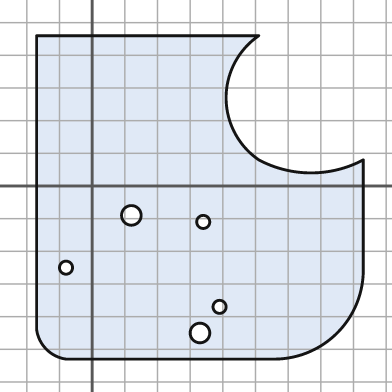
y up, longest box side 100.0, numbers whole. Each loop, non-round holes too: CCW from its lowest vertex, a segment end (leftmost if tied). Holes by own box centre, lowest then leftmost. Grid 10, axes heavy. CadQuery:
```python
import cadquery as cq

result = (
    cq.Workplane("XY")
    .moveTo(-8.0, -53.0)
    .lineTo(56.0, -53.0)
    .threePointArc((75.0, -45.0), (83.0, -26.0))
    .lineTo(83.0, 8.0)
    .threePointArc((67.0, 4.0), (51.0, 8.0))
    .threePointArc((41.0, 27.0), (51.0, 46.0))
    .lineTo(-17.0, 46.0)
    .lineTo(-17.0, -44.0)
    .threePointArc((-14.0, -50.0), (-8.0, -53.0))
    .close()
    .moveTo(33.0, -45.0)
    .circle(3.0)
    .moveTo(39.0, -37.0)
    .circle(2.0)
    .moveTo(-8.0, -25.0)
    .circle(2.0)
    .moveTo(34.0, -11.0)
    .circle(2.0)
    .moveTo(12.0, -9.0)
    .circle(3.0)
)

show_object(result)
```